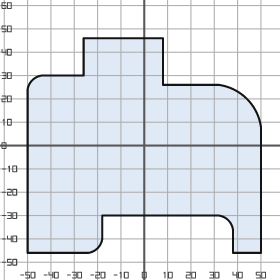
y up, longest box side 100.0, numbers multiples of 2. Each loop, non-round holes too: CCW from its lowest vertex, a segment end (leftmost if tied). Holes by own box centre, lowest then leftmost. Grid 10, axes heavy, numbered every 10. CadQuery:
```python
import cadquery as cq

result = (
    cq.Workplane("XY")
    .moveTo(-50.0, -46.0)
    .lineTo(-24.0, -46.0)
    .threePointArc((-20.0, -44.0), (-18.0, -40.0))
    .lineTo(-18.0, -30.0)
    .lineTo(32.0, -30.0)
    .threePointArc((36.0, -32.0), (38.0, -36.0))
    .lineTo(38.0, -46.0)
    .lineTo(50.0, -46.0)
    .lineTo(50.0, 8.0)
    .threePointArc((44.0, 20.0), (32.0, 26.0))
    .lineTo(8.0, 26.0)
    .lineTo(8.0, 46.0)
    .lineTo(-26.0, 46.0)
    .lineTo(-26.0, 30.0)
    .lineTo(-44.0, 30.0)
    .threePointArc((-48.0, 28.0), (-50.0, 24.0))
    .close()
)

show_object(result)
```